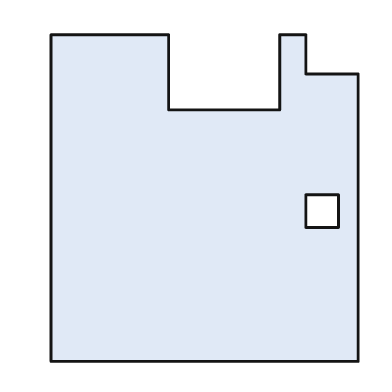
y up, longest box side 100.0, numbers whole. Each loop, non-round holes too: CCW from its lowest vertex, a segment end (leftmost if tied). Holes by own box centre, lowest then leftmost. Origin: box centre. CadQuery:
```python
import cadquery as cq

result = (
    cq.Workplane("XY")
    .moveTo(-47.0, -50.0)
    .lineTo(47.0, -50.0)
    .lineTo(47.0, 38.0)
    .lineTo(31.0, 38.0)
    .lineTo(31.0, 50.0)
    .lineTo(23.0, 50.0)
    .lineTo(23.0, 27.0)
    .lineTo(-11.0, 27.0)
    .lineTo(-11.0, 50.0)
    .lineTo(-47.0, 50.0)
    .close()
    .moveTo(31.0, -9.0)
    .lineTo(41.0, -9.0)
    .lineTo(41.0, 1.0)
    .lineTo(31.0, 1.0)
    .close()
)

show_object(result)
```